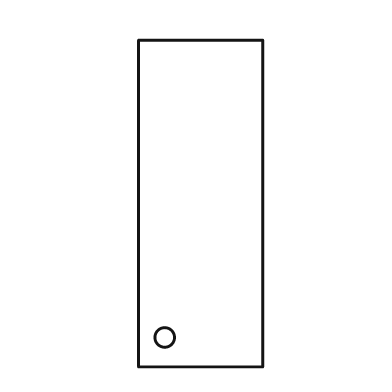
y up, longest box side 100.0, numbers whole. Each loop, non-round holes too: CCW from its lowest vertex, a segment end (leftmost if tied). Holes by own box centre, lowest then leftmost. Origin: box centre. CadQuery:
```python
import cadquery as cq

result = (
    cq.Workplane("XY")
    .moveTo(-19.0, -50.0)
    .lineTo(19.0, -50.0)
    .lineTo(19.0, 50.0)
    .lineTo(-19.0, 50.0)
    .close()
    .moveTo(-11.0, -41.0)
    .circle(3.0)
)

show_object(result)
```